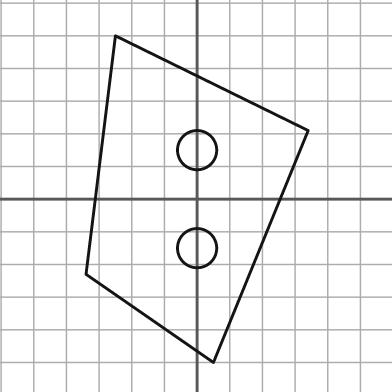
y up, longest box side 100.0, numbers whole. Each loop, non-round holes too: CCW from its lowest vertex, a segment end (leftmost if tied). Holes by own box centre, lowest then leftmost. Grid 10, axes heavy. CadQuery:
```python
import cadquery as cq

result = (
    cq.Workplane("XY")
    .moveTo(5.0, -50.0)
    .lineTo(34.0, 21.0)
    .lineTo(-25.0, 50.0)
    .lineTo(-34.0, -23.0)
    .close()
    .moveTo(0.0, -15.0)
    .circle(6.0)
    .moveTo(0.0, 15.0)
    .circle(6.0)
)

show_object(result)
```